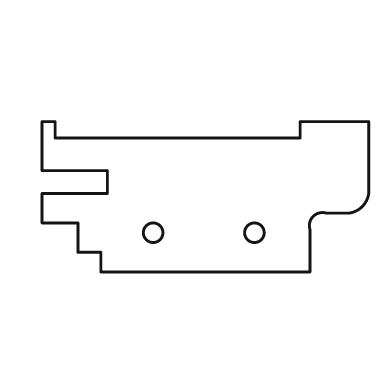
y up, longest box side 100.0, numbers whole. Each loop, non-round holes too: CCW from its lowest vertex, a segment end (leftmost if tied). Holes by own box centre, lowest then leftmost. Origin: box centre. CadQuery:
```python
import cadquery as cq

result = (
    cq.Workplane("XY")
    .moveTo(-32.0, -23.0)
    .lineTo(32.0, -23.0)
    .lineTo(32.0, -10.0)
    .threePointArc((33.0, -6.0), (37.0, -5.0))
    .lineTo(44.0, -5.0)
    .threePointArc((48.0, -3.0), (50.0, 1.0))
    .lineTo(50.0, 23.0)
    .lineTo(29.0, 23.0)
    .lineTo(29.0, 18.0)
    .lineTo(-46.0, 18.0)
    .lineTo(-46.0, 23.0)
    .lineTo(-50.0, 23.0)
    .lineTo(-50.0, 8.0)
    .lineTo(-30.0, 8.0)
    .lineTo(-30.0, 1.0)
    .lineTo(-50.0, 1.0)
    .lineTo(-50.0, -8.0)
    .lineTo(-39.0, -8.0)
    .lineTo(-39.0, -17.0)
    .lineTo(-32.0, -17.0)
    .close()
    .moveTo(-16.0, -11.0)
    .circle(3.0)
    .moveTo(15.0, -11.0)
    .circle(3.0)
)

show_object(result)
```